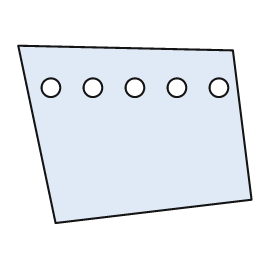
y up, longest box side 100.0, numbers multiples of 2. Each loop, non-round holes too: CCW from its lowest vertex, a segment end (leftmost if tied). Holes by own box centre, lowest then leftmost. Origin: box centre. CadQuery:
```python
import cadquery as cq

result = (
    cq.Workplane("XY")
    .moveTo(-34.0, -38.0)
    .lineTo(50.0, -28.0)
    .lineTo(42.0, 36.0)
    .lineTo(-50.0, 38.0)
    .close()
    .moveTo(-36.0, 20.0)
    .circle(4.0)
    .moveTo(-18.0, 20.0)
    .circle(4.0)
    .moveTo(0.0, 20.0)
    .circle(4.0)
    .moveTo(18.0, 20.0)
    .circle(4.0)
    .moveTo(36.0, 20.0)
    .circle(4.0)
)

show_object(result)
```